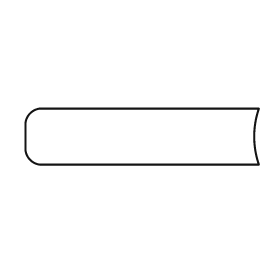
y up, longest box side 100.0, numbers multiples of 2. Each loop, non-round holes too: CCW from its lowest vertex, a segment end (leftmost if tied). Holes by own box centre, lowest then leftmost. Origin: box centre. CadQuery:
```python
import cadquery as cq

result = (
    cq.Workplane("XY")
    .moveTo(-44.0, -12.0)
    .lineTo(50.0, -12.0)
    .threePointArc((48.0, 0.0), (50.0, 12.0))
    .lineTo(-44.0, 12.0)
    .threePointArc((-48.0, 10.0), (-50.0, 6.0))
    .lineTo(-50.0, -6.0)
    .threePointArc((-48.0, -10.0), (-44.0, -12.0))
    .close()
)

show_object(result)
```